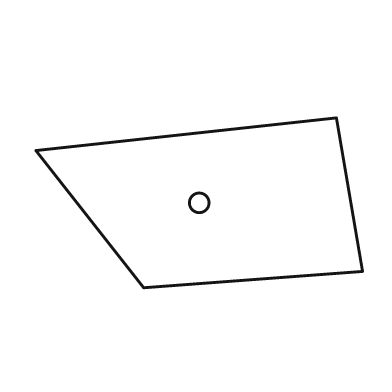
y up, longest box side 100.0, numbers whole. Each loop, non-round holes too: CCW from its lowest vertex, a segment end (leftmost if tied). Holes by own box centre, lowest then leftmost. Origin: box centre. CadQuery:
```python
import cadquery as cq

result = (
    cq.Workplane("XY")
    .moveTo(-17.0, -26.0)
    .lineTo(50.0, -21.0)
    .lineTo(42.0, 26.0)
    .lineTo(-50.0, 16.0)
    .close()
    .moveTo(0.0, 0.0)
    .circle(3.0)
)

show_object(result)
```